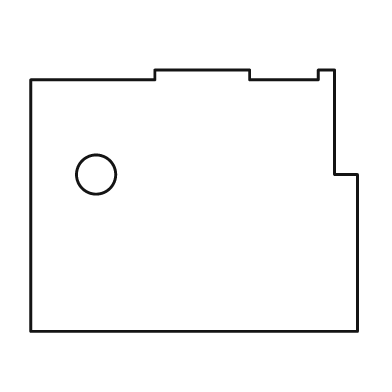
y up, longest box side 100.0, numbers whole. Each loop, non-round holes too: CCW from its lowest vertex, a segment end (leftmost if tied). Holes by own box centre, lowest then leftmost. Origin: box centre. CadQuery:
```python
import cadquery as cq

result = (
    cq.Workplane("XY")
    .moveTo(-50.0, -40.0)
    .lineTo(50.0, -40.0)
    .lineTo(50.0, 8.0)
    .lineTo(43.0, 8.0)
    .lineTo(43.0, 40.0)
    .lineTo(38.0, 40.0)
    .lineTo(38.0, 37.0)
    .lineTo(17.0, 37.0)
    .lineTo(17.0, 40.0)
    .lineTo(-12.0, 40.0)
    .lineTo(-12.0, 37.0)
    .lineTo(-50.0, 37.0)
    .close()
    .moveTo(-30.0, 8.0)
    .circle(6.0)
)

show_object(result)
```